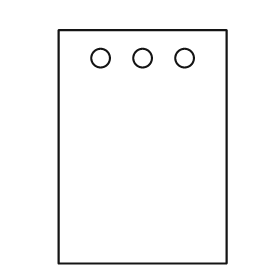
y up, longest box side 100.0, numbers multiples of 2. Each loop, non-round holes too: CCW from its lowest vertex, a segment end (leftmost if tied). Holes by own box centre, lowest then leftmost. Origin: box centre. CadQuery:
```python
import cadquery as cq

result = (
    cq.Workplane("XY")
    .moveTo(-36.0, -50.0)
    .lineTo(36.0, -50.0)
    .lineTo(36.0, 50.0)
    .lineTo(-36.0, 50.0)
    .close()
    .moveTo(-18.0, 38.0)
    .circle(4.0)
    .moveTo(0.0, 38.0)
    .circle(4.0)
    .moveTo(18.0, 38.0)
    .circle(4.0)
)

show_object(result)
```